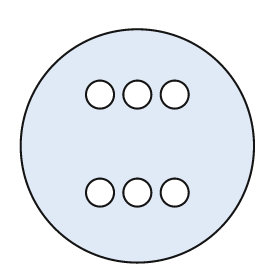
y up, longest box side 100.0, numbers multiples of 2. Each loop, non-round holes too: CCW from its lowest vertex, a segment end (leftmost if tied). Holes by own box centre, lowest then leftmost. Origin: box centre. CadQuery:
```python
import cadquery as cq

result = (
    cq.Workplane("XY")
    .moveTo(0.0, 0.0)
    .circle(50.0)
    .moveTo(-16.0, -20.0)
    .circle(6.0)
    .moveTo(0.0, -20.0)
    .circle(6.0)
    .moveTo(16.0, -20.0)
    .circle(6.0)
    .moveTo(-16.0, 22.0)
    .circle(6.0)
    .moveTo(0.0, 22.0)
    .circle(6.0)
    .moveTo(16.0, 22.0)
    .circle(6.0)
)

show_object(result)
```